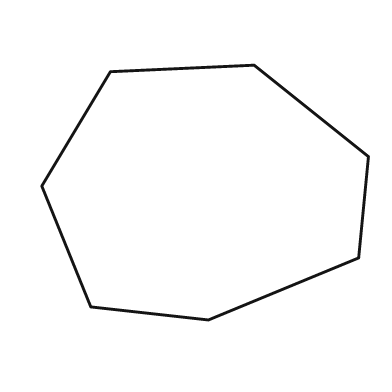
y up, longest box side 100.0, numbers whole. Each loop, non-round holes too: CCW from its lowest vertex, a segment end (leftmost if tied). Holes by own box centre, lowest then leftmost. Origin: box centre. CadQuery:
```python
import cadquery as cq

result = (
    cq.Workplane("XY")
    .moveTo(1.0, -39.0)
    .lineTo(47.0, -20.0)
    .lineTo(50.0, 11.0)
    .lineTo(15.0, 39.0)
    .lineTo(-29.0, 37.0)
    .lineTo(-50.0, 2.0)
    .lineTo(-35.0, -35.0)
    .close()
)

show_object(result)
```